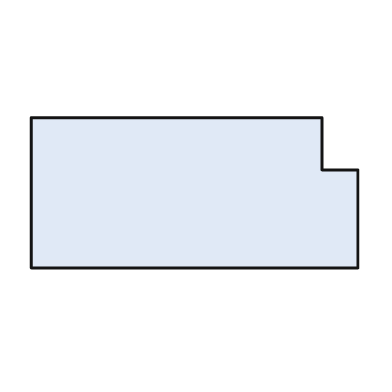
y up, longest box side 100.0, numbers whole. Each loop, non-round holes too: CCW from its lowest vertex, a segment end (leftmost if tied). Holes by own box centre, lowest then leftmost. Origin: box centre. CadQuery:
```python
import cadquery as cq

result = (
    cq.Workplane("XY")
    .moveTo(-50.0, -23.0)
    .lineTo(50.0, -23.0)
    .lineTo(50.0, 7.0)
    .lineTo(39.0, 7.0)
    .lineTo(39.0, 23.0)
    .lineTo(-50.0, 23.0)
    .close()
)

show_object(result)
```